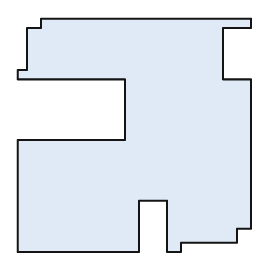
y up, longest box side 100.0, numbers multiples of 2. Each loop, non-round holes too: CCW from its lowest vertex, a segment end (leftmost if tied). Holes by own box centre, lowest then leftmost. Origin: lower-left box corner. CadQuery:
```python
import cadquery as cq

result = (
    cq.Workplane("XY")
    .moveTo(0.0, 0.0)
    .lineTo(52.0, 0.0)
    .lineTo(52.0, 22.0)
    .lineTo(64.0, 22.0)
    .lineTo(64.0, 0.0)
    .lineTo(70.0, 0.0)
    .lineTo(70.0, 4.0)
    .lineTo(94.0, 4.0)
    .lineTo(94.0, 10.0)
    .lineTo(100.0, 10.0)
    .lineTo(100.0, 74.0)
    .lineTo(88.0, 74.0)
    .lineTo(88.0, 96.0)
    .lineTo(100.0, 96.0)
    .lineTo(100.0, 100.0)
    .lineTo(10.0, 100.0)
    .lineTo(10.0, 96.0)
    .lineTo(4.0, 96.0)
    .lineTo(4.0, 78.0)
    .lineTo(0.0, 78.0)
    .lineTo(0.0, 74.0)
    .lineTo(46.0, 74.0)
    .lineTo(46.0, 48.0)
    .lineTo(0.0, 48.0)
    .close()
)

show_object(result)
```